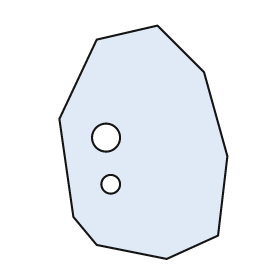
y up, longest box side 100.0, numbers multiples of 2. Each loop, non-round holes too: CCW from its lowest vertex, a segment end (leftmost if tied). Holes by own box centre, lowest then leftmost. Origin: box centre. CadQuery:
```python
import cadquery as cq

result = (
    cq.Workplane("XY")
    .moveTo(10.0, -50.0)
    .lineTo(32.0, -40.0)
    .lineTo(36.0, -6.0)
    .lineTo(26.0, 30.0)
    .lineTo(6.0, 50.0)
    .lineTo(-20.0, 44.0)
    .lineTo(-36.0, 10.0)
    .lineTo(-30.0, -32.0)
    .lineTo(-20.0, -44.0)
    .close()
    .moveTo(-14.0, -18.0)
    .circle(4.0)
    .moveTo(-16.0, 2.0)
    .circle(6.0)
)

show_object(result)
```